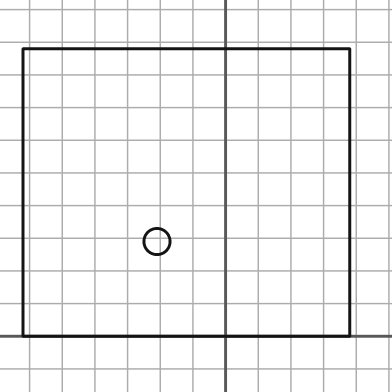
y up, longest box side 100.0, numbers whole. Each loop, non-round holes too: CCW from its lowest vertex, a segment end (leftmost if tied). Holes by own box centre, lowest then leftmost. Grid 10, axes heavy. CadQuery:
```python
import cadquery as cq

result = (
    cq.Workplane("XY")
    .moveTo(-62.0, 0.0)
    .lineTo(38.0, 0.0)
    .lineTo(38.0, 88.0)
    .lineTo(-62.0, 88.0)
    .close()
    .moveTo(-21.0, 29.0)
    .circle(4.0)
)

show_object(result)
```